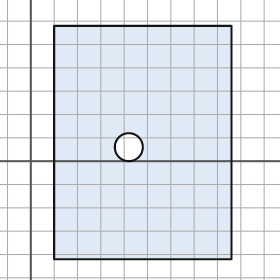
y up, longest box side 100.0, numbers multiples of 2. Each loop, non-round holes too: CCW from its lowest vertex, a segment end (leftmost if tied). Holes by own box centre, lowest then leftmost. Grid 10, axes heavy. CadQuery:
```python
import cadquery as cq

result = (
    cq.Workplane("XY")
    .moveTo(10.0, -42.0)
    .lineTo(86.0, -42.0)
    .lineTo(86.0, 58.0)
    .lineTo(10.0, 58.0)
    .close()
    .moveTo(42.0, 6.0)
    .circle(6.0)
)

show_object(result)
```